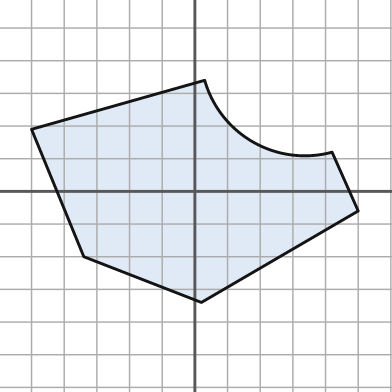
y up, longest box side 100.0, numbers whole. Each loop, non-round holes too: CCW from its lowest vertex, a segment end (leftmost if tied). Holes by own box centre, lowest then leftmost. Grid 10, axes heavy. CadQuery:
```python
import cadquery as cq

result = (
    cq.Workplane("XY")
    .moveTo(2.0, -34.0)
    .lineTo(50.0, -6.0)
    .lineTo(42.0, 12.0)
    .threePointArc((18.0, 15.0), (3.0, 34.0))
    .lineTo(-50.0, 19.0)
    .lineTo(-34.0, -20.0)
    .close()
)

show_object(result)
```